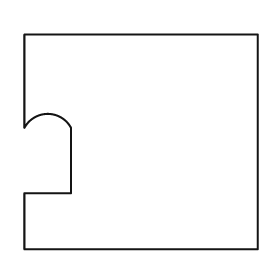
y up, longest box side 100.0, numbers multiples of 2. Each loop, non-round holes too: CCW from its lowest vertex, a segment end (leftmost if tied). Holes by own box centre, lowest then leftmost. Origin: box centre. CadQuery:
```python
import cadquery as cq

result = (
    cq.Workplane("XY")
    .moveTo(-50.0, -46.0)
    .lineTo(50.0, -46.0)
    .lineTo(50.0, 46.0)
    .lineTo(-50.0, 46.0)
    .lineTo(-50.0, 6.0)
    .threePointArc((-40.0, 12.0), (-30.0, 6.0))
    .lineTo(-30.0, -22.0)
    .lineTo(-50.0, -22.0)
    .close()
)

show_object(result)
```